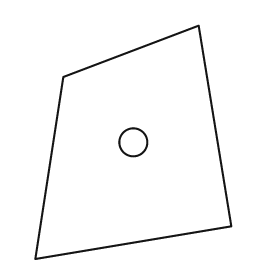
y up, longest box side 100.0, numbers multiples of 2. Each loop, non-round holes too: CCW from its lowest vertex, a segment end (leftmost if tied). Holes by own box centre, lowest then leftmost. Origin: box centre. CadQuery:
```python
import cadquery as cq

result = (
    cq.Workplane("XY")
    .moveTo(-42.0, -50.0)
    .lineTo(42.0, -36.0)
    .lineTo(28.0, 50.0)
    .lineTo(-30.0, 28.0)
    .close()
    .moveTo(0.0, 0.0)
    .circle(6.0)
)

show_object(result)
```